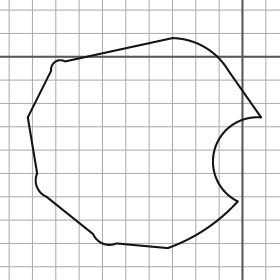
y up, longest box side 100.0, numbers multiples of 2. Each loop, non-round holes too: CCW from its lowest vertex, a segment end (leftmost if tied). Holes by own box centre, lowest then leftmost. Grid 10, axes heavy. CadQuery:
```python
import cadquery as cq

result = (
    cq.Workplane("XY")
    .moveTo(-32.0, -82.0)
    .threePointArc((-16.0, -74.0), (-2.0, -62.0))
    .threePointArc((-12.0, -40.0), (8.0, -26.0))
    .lineTo(-6.0, -6.0)
    .threePointArc((-16.0, 4.0), (-30.0, 8.0))
    .lineTo(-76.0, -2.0)
    .threePointArc((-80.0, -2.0), (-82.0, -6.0))
    .lineTo(-92.0, -26.0)
    .lineTo(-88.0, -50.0)
    .threePointArc((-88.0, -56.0), (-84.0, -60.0))
    .lineTo(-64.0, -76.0)
    .threePointArc((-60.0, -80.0), (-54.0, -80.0))
    .close()
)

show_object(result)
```